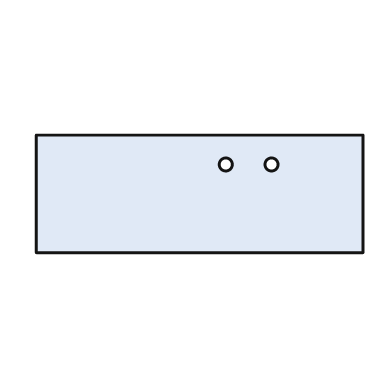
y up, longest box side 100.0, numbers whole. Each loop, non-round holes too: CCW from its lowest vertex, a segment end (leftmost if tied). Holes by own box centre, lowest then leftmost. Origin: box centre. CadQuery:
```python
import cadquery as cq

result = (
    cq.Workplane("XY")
    .moveTo(-50.0, -18.0)
    .lineTo(50.0, -18.0)
    .lineTo(50.0, 18.0)
    .lineTo(-50.0, 18.0)
    .close()
    .moveTo(8.0, 9.0)
    .circle(2.0)
    .moveTo(22.0, 9.0)
    .circle(2.0)
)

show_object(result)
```